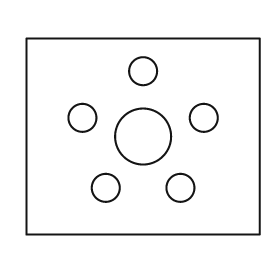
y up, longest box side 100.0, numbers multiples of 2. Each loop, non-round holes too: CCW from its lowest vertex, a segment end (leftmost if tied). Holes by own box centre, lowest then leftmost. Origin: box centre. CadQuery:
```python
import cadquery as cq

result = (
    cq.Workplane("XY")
    .moveTo(-50.0, -42.0)
    .lineTo(50.0, -42.0)
    .lineTo(50.0, 42.0)
    .lineTo(-50.0, 42.0)
    .close()
    .moveTo(-16.0, -22.0)
    .circle(6.0)
    .moveTo(16.0, -22.0)
    .circle(6.0)
    .moveTo(0.0, 0.0)
    .circle(12.0)
    .moveTo(-26.0, 8.0)
    .circle(6.0)
    .moveTo(26.0, 8.0)
    .circle(6.0)
    .moveTo(0.0, 28.0)
    .circle(6.0)
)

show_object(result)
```